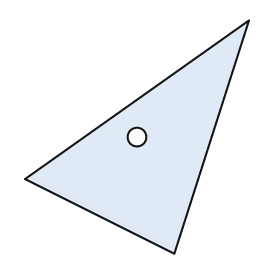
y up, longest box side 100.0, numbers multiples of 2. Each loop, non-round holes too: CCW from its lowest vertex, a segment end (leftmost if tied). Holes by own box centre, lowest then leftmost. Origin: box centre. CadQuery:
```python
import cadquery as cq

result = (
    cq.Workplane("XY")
    .moveTo(16.0, -50.0)
    .lineTo(48.0, 50.0)
    .lineTo(-48.0, -18.0)
    .close()
    .moveTo(0.0, 0.0)
    .circle(4.0)
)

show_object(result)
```